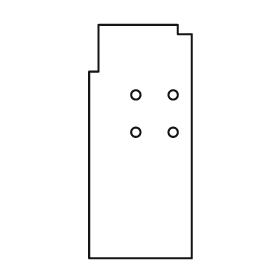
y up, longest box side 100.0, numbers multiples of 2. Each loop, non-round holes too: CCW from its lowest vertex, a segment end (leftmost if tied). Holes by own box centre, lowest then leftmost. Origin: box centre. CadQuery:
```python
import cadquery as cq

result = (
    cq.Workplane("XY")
    .moveTo(-22.0, -50.0)
    .lineTo(22.0, -50.0)
    .lineTo(22.0, 46.0)
    .lineTo(16.0, 46.0)
    .lineTo(16.0, 50.0)
    .lineTo(-18.0, 50.0)
    .lineTo(-18.0, 30.0)
    .lineTo(-22.0, 30.0)
    .close()
    .moveTo(-2.0, 4.0)
    .circle(2.0)
    .moveTo(14.0, 4.0)
    .circle(2.0)
    .moveTo(-2.0, 20.0)
    .circle(2.0)
    .moveTo(14.0, 20.0)
    .circle(2.0)
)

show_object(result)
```